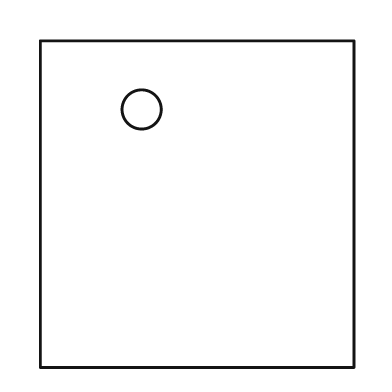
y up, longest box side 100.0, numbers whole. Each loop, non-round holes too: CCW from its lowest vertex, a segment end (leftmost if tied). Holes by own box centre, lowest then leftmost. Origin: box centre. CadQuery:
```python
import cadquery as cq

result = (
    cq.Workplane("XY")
    .moveTo(-48.0, -50.0)
    .lineTo(48.0, -50.0)
    .lineTo(48.0, 50.0)
    .lineTo(-48.0, 50.0)
    .close()
    .moveTo(-17.0, 29.0)
    .circle(6.0)
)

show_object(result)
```